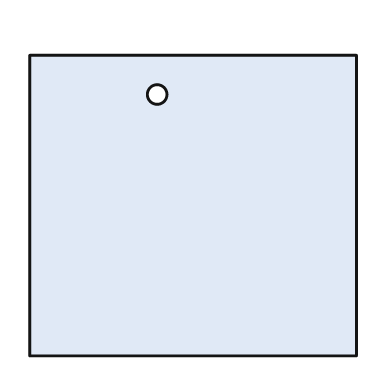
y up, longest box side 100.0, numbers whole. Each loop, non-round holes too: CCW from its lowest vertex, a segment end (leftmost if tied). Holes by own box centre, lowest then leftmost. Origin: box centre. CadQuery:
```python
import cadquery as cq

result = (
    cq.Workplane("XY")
    .moveTo(-50.0, -46.0)
    .lineTo(50.0, -46.0)
    .lineTo(50.0, 46.0)
    .lineTo(-50.0, 46.0)
    .close()
    .moveTo(-11.0, 34.0)
    .circle(3.0)
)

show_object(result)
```